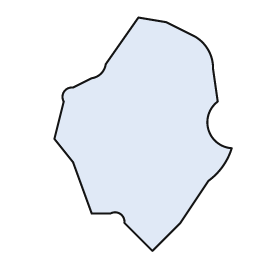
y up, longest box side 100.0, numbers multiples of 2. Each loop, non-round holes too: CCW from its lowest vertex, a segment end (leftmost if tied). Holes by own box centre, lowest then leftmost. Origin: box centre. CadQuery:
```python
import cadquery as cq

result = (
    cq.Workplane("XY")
    .moveTo(4.0, -50.0)
    .lineTo(16.0, -38.0)
    .lineTo(28.0, -20.0)
    .threePointArc((34.0, -14.0), (38.0, -6.0))
    .threePointArc((28.0, 2.0), (32.0, 14.0))
    .lineTo(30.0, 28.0)
    .threePointArc((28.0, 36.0), (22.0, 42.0))
    .lineTo(10.0, 48.0)
    .lineTo(-2.0, 50.0)
    .lineTo(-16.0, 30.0)
    .threePointArc((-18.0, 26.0), (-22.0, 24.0))
    .lineTo(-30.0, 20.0)
    .threePointArc((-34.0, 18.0), (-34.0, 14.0))
    .lineTo(-38.0, -2.0)
    .lineTo(-30.0, -12.0)
    .lineTo(-22.0, -34.0)
    .lineTo(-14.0, -34.0)
    .threePointArc((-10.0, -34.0), (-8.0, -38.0))
    .close()
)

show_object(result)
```